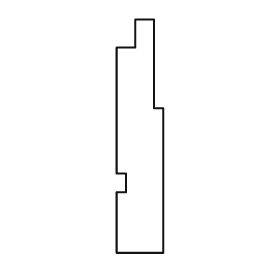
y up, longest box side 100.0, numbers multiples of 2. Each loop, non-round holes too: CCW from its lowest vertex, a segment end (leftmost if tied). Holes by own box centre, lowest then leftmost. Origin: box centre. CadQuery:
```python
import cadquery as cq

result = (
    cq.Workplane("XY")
    .moveTo(-10.0, -50.0)
    .lineTo(10.0, -50.0)
    .lineTo(10.0, 12.0)
    .lineTo(6.0, 12.0)
    .lineTo(6.0, 50.0)
    .lineTo(-2.0, 50.0)
    .lineTo(-2.0, 38.0)
    .lineTo(-10.0, 38.0)
    .lineTo(-10.0, -16.0)
    .lineTo(-6.0, -16.0)
    .lineTo(-6.0, -24.0)
    .lineTo(-10.0, -24.0)
    .close()
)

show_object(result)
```